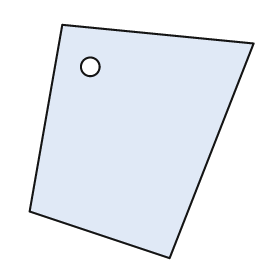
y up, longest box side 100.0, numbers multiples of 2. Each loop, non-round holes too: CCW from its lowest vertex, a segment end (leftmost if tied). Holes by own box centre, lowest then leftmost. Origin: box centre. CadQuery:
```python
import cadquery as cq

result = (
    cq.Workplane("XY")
    .moveTo(12.0, -50.0)
    .lineTo(48.0, 42.0)
    .lineTo(-34.0, 50.0)
    .lineTo(-48.0, -30.0)
    .close()
    .moveTo(-22.0, 32.0)
    .circle(4.0)
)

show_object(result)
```